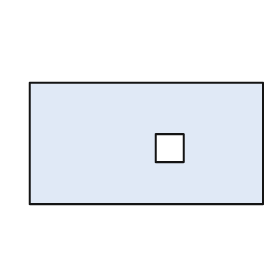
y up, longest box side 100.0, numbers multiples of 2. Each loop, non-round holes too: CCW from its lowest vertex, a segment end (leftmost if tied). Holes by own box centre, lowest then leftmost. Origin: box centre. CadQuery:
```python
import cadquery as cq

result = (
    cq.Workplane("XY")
    .moveTo(-50.0, -26.0)
    .lineTo(50.0, -26.0)
    .lineTo(50.0, 26.0)
    .lineTo(-50.0, 26.0)
    .close()
    .moveTo(4.0, -8.0)
    .lineTo(16.0, -8.0)
    .lineTo(16.0, 4.0)
    .lineTo(4.0, 4.0)
    .close()
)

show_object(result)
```